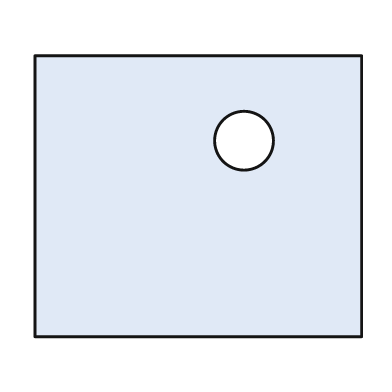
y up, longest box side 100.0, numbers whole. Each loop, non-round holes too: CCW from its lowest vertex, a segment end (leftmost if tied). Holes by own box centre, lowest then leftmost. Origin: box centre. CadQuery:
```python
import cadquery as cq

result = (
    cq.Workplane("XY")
    .moveTo(-50.0, -43.0)
    .lineTo(50.0, -43.0)
    .lineTo(50.0, 43.0)
    .lineTo(-50.0, 43.0)
    .close()
    .moveTo(14.0, 17.0)
    .circle(9.0)
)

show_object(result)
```